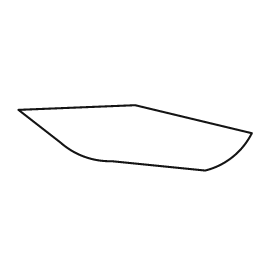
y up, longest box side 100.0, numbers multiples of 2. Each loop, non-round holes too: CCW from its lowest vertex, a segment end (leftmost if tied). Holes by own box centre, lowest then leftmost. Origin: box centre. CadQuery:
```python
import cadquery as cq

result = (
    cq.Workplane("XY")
    .moveTo(30.0, -14.0)
    .threePointArc((42.0, -8.0), (50.0, 2.0))
    .lineTo(0.0, 14.0)
    .lineTo(-50.0, 12.0)
    .lineTo(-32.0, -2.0)
    .threePointArc((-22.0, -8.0), (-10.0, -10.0))
    .close()
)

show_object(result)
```